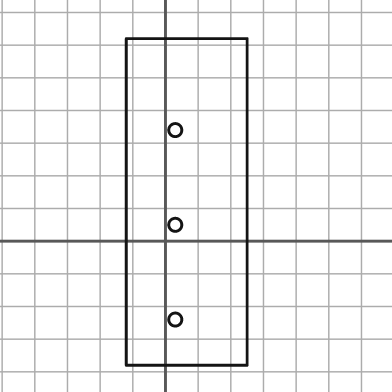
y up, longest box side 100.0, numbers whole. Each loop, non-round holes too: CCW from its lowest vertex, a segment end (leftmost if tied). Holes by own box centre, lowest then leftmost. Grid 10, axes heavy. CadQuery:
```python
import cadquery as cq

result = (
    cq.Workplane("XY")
    .moveTo(-12.0, -38.0)
    .lineTo(25.0, -38.0)
    .lineTo(25.0, 62.0)
    .lineTo(-12.0, 62.0)
    .close()
    .moveTo(3.0, -24.0)
    .circle(2.0)
    .moveTo(3.0, 5.0)
    .circle(2.0)
    .moveTo(3.0, 34.0)
    .circle(2.0)
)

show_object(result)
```